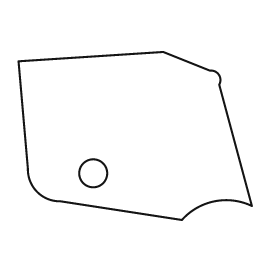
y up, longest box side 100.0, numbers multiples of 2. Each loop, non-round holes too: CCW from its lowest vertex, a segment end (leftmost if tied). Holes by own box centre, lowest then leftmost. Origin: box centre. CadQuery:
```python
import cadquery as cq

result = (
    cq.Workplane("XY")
    .moveTo(20.0, -36.0)
    .threePointArc((34.0, -28.0), (50.0, -30.0))
    .lineTo(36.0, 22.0)
    .threePointArc((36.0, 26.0), (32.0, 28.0))
    .lineTo(12.0, 36.0)
    .lineTo(-50.0, 32.0)
    .lineTo(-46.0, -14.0)
    .threePointArc((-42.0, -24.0), (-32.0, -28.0))
    .close()
    .moveTo(-18.0, -16.0)
    .circle(6.0)
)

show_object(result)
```